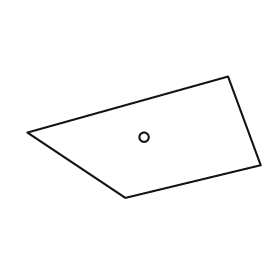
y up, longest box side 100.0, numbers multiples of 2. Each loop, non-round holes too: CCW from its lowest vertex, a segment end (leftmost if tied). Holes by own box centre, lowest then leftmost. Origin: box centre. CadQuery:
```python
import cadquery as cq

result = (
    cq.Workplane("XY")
    .moveTo(-8.0, -26.0)
    .lineTo(50.0, -12.0)
    .lineTo(36.0, 26.0)
    .lineTo(-50.0, 2.0)
    .close()
    .moveTo(0.0, 0.0)
    .circle(2.0)
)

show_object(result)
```